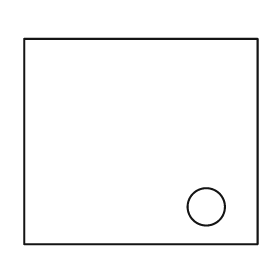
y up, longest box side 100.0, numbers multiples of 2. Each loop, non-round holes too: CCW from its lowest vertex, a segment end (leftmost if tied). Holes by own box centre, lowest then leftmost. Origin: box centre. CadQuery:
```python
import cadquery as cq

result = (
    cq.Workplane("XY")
    .moveTo(-50.0, -44.0)
    .lineTo(50.0, -44.0)
    .lineTo(50.0, 44.0)
    .lineTo(-50.0, 44.0)
    .close()
    .moveTo(28.0, -28.0)
    .circle(8.0)
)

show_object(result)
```